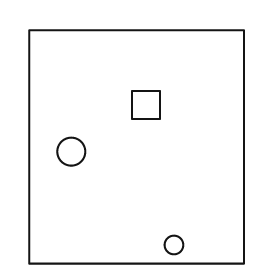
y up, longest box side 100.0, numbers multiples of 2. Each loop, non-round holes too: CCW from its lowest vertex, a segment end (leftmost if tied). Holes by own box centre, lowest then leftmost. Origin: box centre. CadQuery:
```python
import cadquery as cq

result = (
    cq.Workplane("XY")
    .moveTo(-46.0, -50.0)
    .lineTo(46.0, -50.0)
    .lineTo(46.0, 50.0)
    .lineTo(-46.0, 50.0)
    .close()
    .moveTo(16.0, -42.0)
    .circle(4.0)
    .moveTo(-28.0, -2.0)
    .circle(6.0)
    .moveTo(-2.0, 12.0)
    .lineTo(10.0, 12.0)
    .lineTo(10.0, 24.0)
    .lineTo(-2.0, 24.0)
    .close()
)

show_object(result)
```